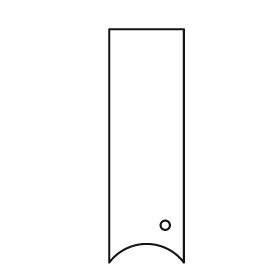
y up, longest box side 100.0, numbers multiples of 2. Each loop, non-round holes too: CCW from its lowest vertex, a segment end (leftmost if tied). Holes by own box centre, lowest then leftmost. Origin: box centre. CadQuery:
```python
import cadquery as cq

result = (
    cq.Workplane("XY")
    .moveTo(-16.0, -50.0)
    .threePointArc((0.0, -42.0), (16.0, -50.0))
    .lineTo(16.0, 50.0)
    .lineTo(-16.0, 50.0)
    .close()
    .moveTo(8.0, -34.0)
    .circle(2.0)
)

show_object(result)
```